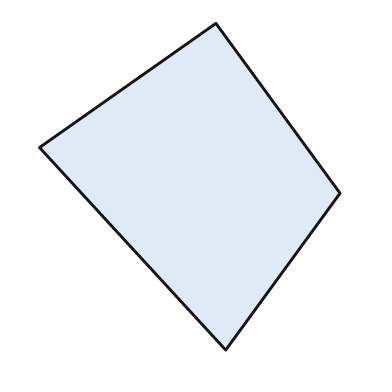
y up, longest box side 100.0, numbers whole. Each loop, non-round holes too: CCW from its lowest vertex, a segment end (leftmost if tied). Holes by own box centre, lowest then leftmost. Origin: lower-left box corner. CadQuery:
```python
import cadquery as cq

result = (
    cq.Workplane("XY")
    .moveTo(57.0, 0.0)
    .lineTo(92.0, 48.0)
    .lineTo(54.0, 100.0)
    .lineTo(0.0, 62.0)
    .close()
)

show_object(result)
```